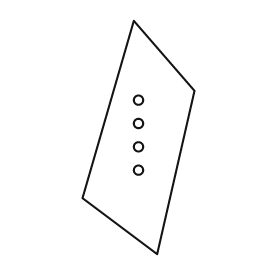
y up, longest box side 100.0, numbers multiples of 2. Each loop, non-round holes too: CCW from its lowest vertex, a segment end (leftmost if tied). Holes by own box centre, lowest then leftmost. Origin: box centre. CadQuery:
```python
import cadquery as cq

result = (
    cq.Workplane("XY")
    .moveTo(8.0, -50.0)
    .lineTo(24.0, 20.0)
    .lineTo(-2.0, 50.0)
    .lineTo(-24.0, -26.0)
    .close()
    .moveTo(0.0, -14.0)
    .circle(2.0)
    .moveTo(0.0, -4.0)
    .circle(2.0)
    .moveTo(0.0, 6.0)
    .circle(2.0)
    .moveTo(0.0, 16.0)
    .circle(2.0)
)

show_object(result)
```